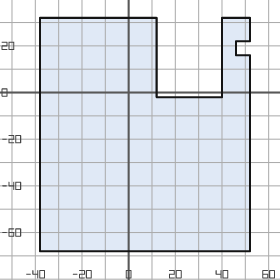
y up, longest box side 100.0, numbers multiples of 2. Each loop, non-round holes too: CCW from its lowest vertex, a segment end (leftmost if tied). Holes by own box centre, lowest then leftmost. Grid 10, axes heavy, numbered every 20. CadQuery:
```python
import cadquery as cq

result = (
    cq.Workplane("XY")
    .moveTo(-38.0, -68.0)
    .lineTo(52.0, -68.0)
    .lineTo(52.0, 16.0)
    .lineTo(46.0, 16.0)
    .lineTo(46.0, 22.0)
    .lineTo(52.0, 22.0)
    .lineTo(52.0, 32.0)
    .lineTo(40.0, 32.0)
    .lineTo(40.0, -2.0)
    .lineTo(12.0, -2.0)
    .lineTo(12.0, 32.0)
    .lineTo(-38.0, 32.0)
    .close()
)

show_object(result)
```